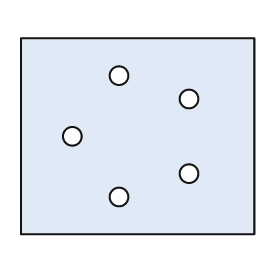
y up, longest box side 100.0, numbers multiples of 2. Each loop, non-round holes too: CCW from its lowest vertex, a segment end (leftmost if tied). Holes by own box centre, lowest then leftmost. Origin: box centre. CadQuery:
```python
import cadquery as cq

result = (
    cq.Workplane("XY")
    .moveTo(-50.0, -42.0)
    .lineTo(50.0, -42.0)
    .lineTo(50.0, 42.0)
    .lineTo(-50.0, 42.0)
    .close()
    .moveTo(-8.0, -26.0)
    .circle(4.0)
    .moveTo(22.0, -16.0)
    .circle(4.0)
    .moveTo(-28.0, 0.0)
    .circle(4.0)
    .moveTo(22.0, 16.0)
    .circle(4.0)
    .moveTo(-8.0, 26.0)
    .circle(4.0)
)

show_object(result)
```